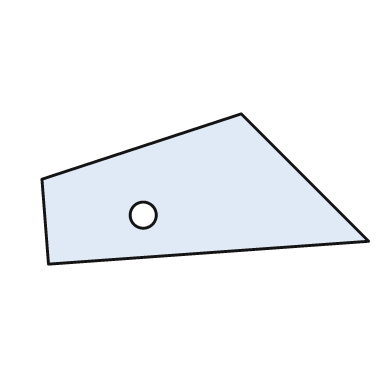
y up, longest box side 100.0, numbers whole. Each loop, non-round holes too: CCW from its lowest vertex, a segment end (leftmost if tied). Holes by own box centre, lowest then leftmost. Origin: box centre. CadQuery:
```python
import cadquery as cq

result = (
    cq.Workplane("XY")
    .moveTo(-48.0, -23.0)
    .lineTo(50.0, -16.0)
    .lineTo(11.0, 23.0)
    .lineTo(-50.0, 3.0)
    .close()
    .moveTo(-19.0, -8.0)
    .circle(4.0)
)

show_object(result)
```